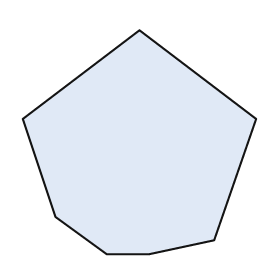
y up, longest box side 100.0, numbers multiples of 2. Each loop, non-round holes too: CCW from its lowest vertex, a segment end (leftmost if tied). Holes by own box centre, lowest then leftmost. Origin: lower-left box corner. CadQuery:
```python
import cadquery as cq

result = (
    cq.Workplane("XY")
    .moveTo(36.0, 0.0)
    .lineTo(54.0, 0.0)
    .lineTo(82.0, 6.0)
    .lineTo(100.0, 58.0)
    .lineTo(50.0, 96.0)
    .lineTo(0.0, 58.0)
    .lineTo(14.0, 16.0)
    .close()
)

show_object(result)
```